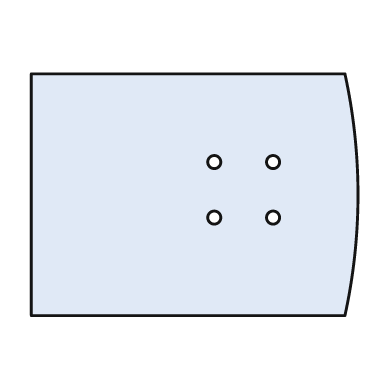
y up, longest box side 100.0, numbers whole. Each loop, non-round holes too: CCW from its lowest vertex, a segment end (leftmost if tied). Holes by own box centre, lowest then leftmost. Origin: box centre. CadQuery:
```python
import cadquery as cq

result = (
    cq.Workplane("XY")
    .moveTo(-50.0, -37.0)
    .lineTo(46.0, -37.0)
    .threePointArc((50.0, 0.0), (46.0, 37.0))
    .lineTo(-50.0, 37.0)
    .close()
    .moveTo(6.0, -7.0)
    .circle(2.0)
    .moveTo(24.0, -7.0)
    .circle(2.0)
    .moveTo(6.0, 10.0)
    .circle(2.0)
    .moveTo(24.0, 10.0)
    .circle(2.0)
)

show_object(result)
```